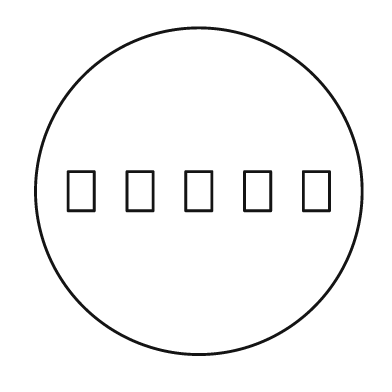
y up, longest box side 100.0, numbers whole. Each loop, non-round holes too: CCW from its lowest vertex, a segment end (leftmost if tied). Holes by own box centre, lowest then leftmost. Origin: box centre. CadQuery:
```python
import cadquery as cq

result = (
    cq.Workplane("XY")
    .moveTo(0.0, 0.0)
    .circle(50.0)
    .moveTo(-40.0, -6.0)
    .lineTo(-32.0, -6.0)
    .lineTo(-32.0, 6.0)
    .lineTo(-40.0, 6.0)
    .close()
    .moveTo(-22.0, -6.0)
    .lineTo(-14.0, -6.0)
    .lineTo(-14.0, 6.0)
    .lineTo(-22.0, 6.0)
    .close()
    .moveTo(-4.0, -6.0)
    .lineTo(4.0, -6.0)
    .lineTo(4.0, 6.0)
    .lineTo(-4.0, 6.0)
    .close()
    .moveTo(14.0, -6.0)
    .lineTo(22.0, -6.0)
    .lineTo(22.0, 6.0)
    .lineTo(14.0, 6.0)
    .close()
    .moveTo(32.0, -6.0)
    .lineTo(40.0, -6.0)
    .lineTo(40.0, 6.0)
    .lineTo(32.0, 6.0)
    .close()
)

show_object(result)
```